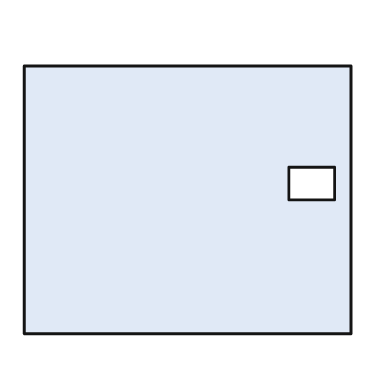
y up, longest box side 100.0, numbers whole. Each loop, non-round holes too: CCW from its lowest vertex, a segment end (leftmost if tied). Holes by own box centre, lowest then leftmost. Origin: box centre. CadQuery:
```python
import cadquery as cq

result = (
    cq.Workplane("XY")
    .moveTo(-50.0, -41.0)
    .lineTo(50.0, -41.0)
    .lineTo(50.0, 41.0)
    .lineTo(-50.0, 41.0)
    .close()
    .moveTo(31.0, 0.0)
    .lineTo(45.0, 0.0)
    .lineTo(45.0, 10.0)
    .lineTo(31.0, 10.0)
    .close()
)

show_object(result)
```